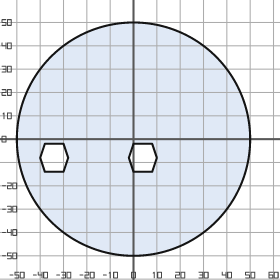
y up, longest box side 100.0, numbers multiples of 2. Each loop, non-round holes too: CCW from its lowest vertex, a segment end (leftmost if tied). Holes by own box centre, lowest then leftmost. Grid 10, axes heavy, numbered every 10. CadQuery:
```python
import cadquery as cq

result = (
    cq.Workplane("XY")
    .moveTo(0.0, 0.0)
    .circle(50.0)
    .moveTo(-38.0, -14.0)
    .lineTo(-30.0, -14.0)
    .lineTo(-28.0, -8.0)
    .lineTo(-30.0, -2.0)
    .lineTo(-38.0, -2.0)
    .lineTo(-40.0, -8.0)
    .close()
    .moveTo(0.0, -14.0)
    .lineTo(8.0, -14.0)
    .lineTo(10.0, -8.0)
    .lineTo(8.0, -2.0)
    .lineTo(0.0, -2.0)
    .lineTo(-2.0, -8.0)
    .close()
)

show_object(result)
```